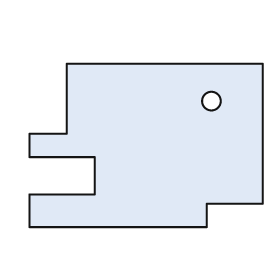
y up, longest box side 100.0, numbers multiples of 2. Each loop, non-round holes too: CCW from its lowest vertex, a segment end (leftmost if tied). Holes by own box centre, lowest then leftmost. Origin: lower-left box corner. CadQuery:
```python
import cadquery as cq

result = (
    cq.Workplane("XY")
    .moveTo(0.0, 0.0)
    .lineTo(76.0, 0.0)
    .lineTo(76.0, 10.0)
    .lineTo(100.0, 10.0)
    .lineTo(100.0, 70.0)
    .lineTo(16.0, 70.0)
    .lineTo(16.0, 40.0)
    .lineTo(0.0, 40.0)
    .lineTo(0.0, 30.0)
    .lineTo(28.0, 30.0)
    .lineTo(28.0, 14.0)
    .lineTo(0.0, 14.0)
    .close()
    .moveTo(78.0, 54.0)
    .circle(4.0)
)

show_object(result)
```